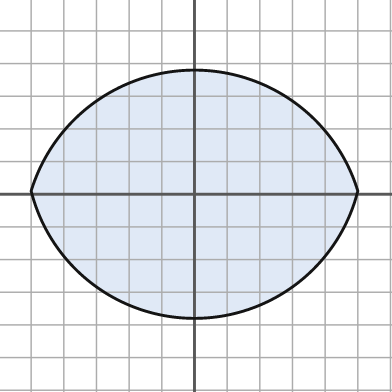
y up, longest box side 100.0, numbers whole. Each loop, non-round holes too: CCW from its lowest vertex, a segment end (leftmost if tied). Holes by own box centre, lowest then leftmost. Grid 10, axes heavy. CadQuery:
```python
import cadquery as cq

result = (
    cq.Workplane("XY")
    .moveTo(-50.0, 1.0)
    .threePointArc((0.0, -38.0), (50.0, 1.0))
    .threePointArc((0.0, 38.0), (-50.0, 1.0))
    .close()
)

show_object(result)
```